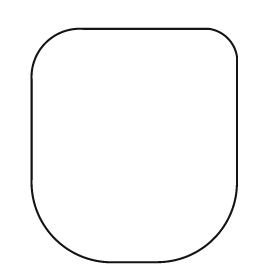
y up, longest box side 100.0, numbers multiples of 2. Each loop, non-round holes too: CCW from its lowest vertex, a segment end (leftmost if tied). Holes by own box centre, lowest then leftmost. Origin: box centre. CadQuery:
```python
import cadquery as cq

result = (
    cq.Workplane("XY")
    .moveTo(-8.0, -50.0)
    .lineTo(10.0, -50.0)
    .threePointArc((34.0, -40.0), (44.0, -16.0))
    .lineTo(44.0, 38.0)
    .threePointArc((40.0, 46.0), (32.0, 50.0))
    .lineTo(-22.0, 50.0)
    .threePointArc((-38.0, 44.0), (-44.0, 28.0))
    .lineTo(-44.0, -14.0)
    .threePointArc((-34.0, -40.0), (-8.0, -50.0))
    .close()
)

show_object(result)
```